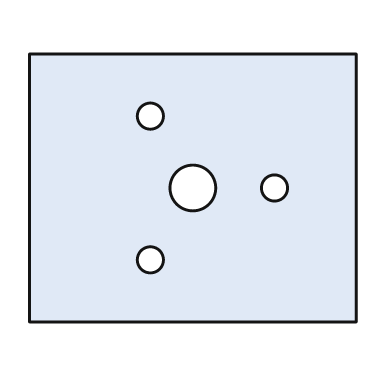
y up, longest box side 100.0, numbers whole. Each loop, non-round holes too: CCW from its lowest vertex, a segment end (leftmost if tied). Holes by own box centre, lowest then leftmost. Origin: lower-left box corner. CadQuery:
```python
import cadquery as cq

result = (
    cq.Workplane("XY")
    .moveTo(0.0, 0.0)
    .lineTo(100.0, 0.0)
    .lineTo(100.0, 82.0)
    .lineTo(0.0, 82.0)
    .close()
    .moveTo(37.0, 19.0)
    .circle(4.0)
    .moveTo(50.0, 41.0)
    .circle(7.0)
    .moveTo(75.0, 41.0)
    .circle(4.0)
    .moveTo(37.0, 63.0)
    .circle(4.0)
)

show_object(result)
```